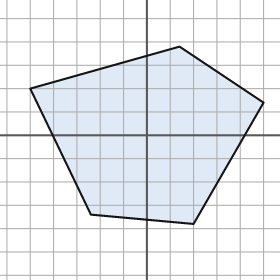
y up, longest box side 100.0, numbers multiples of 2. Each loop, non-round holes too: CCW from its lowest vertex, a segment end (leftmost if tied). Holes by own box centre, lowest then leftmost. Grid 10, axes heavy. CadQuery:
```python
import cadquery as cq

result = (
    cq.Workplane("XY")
    .moveTo(20.0, -38.0)
    .lineTo(50.0, 14.0)
    .lineTo(14.0, 38.0)
    .lineTo(-50.0, 20.0)
    .lineTo(-24.0, -34.0)
    .close()
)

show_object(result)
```